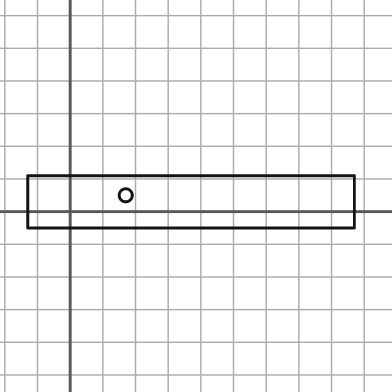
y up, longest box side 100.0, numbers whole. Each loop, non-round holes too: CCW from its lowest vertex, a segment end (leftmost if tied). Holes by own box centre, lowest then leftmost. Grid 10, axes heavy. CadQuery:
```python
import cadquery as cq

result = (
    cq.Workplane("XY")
    .moveTo(-13.0, -5.0)
    .lineTo(87.0, -5.0)
    .lineTo(87.0, 11.0)
    .lineTo(-13.0, 11.0)
    .close()
    .moveTo(17.0, 5.0)
    .circle(2.0)
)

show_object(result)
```